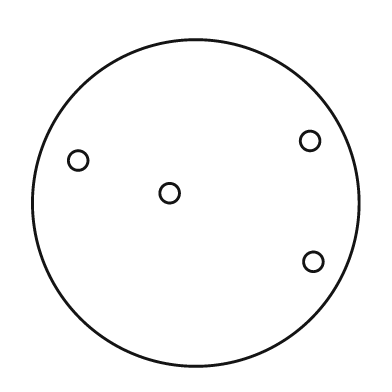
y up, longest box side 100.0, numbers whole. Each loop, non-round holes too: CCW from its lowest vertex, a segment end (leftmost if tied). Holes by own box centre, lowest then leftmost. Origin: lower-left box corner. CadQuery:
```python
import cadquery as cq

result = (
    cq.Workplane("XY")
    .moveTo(50.0, 50.0)
    .circle(50.0)
    .moveTo(86.0, 32.0)
    .circle(3.0)
    .moveTo(42.0, 53.0)
    .circle(3.0)
    .moveTo(14.0, 63.0)
    .circle(3.0)
    .moveTo(85.0, 69.0)
    .circle(3.0)
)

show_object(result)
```